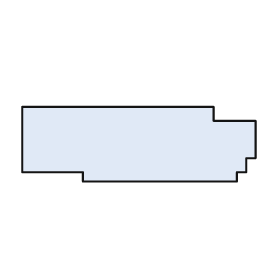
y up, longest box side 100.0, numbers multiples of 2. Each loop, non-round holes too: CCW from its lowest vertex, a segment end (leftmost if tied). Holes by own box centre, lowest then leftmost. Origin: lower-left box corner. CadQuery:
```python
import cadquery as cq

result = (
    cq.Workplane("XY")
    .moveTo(26.0, 0.0)
    .lineTo(92.0, 0.0)
    .lineTo(92.0, 4.0)
    .lineTo(96.0, 4.0)
    .lineTo(96.0, 10.0)
    .lineTo(100.0, 10.0)
    .lineTo(100.0, 26.0)
    .lineTo(82.0, 26.0)
    .lineTo(82.0, 32.0)
    .lineTo(0.0, 32.0)
    .lineTo(0.0, 4.0)
    .lineTo(26.0, 4.0)
    .close()
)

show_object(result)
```